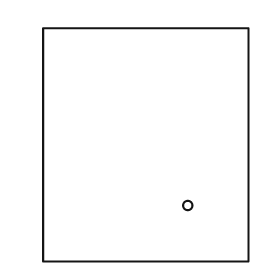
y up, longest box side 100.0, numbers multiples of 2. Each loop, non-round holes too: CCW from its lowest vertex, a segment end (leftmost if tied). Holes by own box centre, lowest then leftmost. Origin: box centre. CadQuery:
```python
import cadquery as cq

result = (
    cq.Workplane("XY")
    .moveTo(-44.0, -50.0)
    .lineTo(44.0, -50.0)
    .lineTo(44.0, 50.0)
    .lineTo(-44.0, 50.0)
    .close()
    .moveTo(18.0, -26.0)
    .circle(2.0)
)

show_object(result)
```